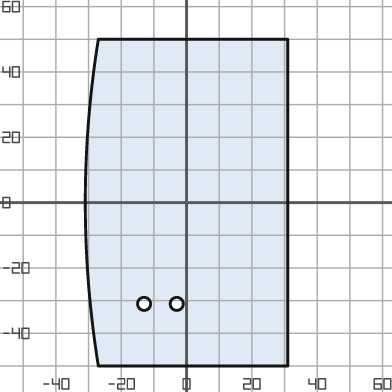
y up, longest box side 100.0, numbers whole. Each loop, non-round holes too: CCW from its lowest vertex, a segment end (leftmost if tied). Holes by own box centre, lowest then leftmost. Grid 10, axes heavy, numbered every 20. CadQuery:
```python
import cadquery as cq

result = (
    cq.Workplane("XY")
    .moveTo(-27.0, -50.0)
    .lineTo(31.0, -50.0)
    .lineTo(31.0, 50.0)
    .lineTo(-27.0, 50.0)
    .threePointArc((-31.0, 0.0), (-27.0, -50.0))
    .close()
    .moveTo(-13.0, -31.0)
    .circle(2.0)
    .moveTo(-3.0, -31.0)
    .circle(2.0)
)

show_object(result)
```